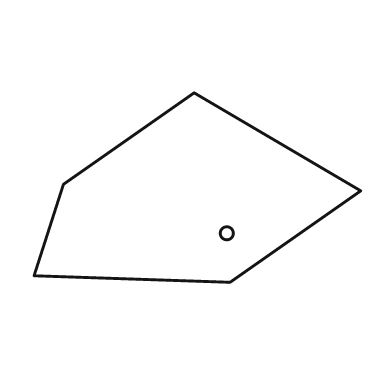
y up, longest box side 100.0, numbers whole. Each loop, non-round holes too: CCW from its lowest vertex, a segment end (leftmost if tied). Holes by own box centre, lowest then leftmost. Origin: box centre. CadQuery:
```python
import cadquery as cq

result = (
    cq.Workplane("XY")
    .moveTo(10.0, -29.0)
    .lineTo(50.0, -1.0)
    .lineTo(-1.0, 29.0)
    .lineTo(-41.0, 1.0)
    .lineTo(-50.0, -27.0)
    .close()
    .moveTo(9.0, -14.0)
    .circle(2.0)
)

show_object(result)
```